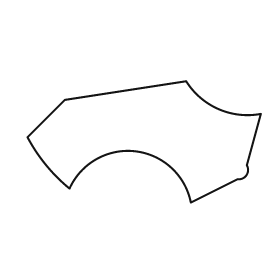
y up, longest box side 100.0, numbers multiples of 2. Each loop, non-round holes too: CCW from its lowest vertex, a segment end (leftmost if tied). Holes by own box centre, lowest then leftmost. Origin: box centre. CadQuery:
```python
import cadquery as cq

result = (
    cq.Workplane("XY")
    .moveTo(20.0, -26.0)
    .lineTo(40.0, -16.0)
    .threePointArc((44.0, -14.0), (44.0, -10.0))
    .lineTo(50.0, 12.0)
    .threePointArc((32.0, 14.0), (18.0, 26.0))
    .lineTo(-34.0, 18.0)
    .lineTo(-50.0, 2.0)
    .threePointArc((-42.0, -10.0), (-32.0, -20.0))
    .threePointArc((-4.0, -4.0), (20.0, -26.0))
    .close()
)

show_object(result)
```